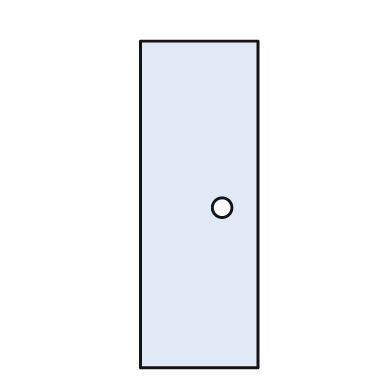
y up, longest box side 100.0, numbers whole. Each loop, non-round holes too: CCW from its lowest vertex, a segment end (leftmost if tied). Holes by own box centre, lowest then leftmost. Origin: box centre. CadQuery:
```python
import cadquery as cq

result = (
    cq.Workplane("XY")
    .moveTo(-18.0, -50.0)
    .lineTo(18.0, -50.0)
    .lineTo(18.0, 50.0)
    .lineTo(-18.0, 50.0)
    .close()
    .moveTo(7.0, -1.0)
    .circle(3.0)
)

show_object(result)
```